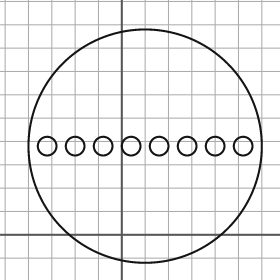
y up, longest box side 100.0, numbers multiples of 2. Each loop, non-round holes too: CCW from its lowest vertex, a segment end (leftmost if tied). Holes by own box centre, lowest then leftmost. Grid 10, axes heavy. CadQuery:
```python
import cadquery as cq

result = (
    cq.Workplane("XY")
    .moveTo(10.0, 38.0)
    .circle(50.0)
    .moveTo(-32.0, 38.0)
    .circle(4.0)
    .moveTo(-20.0, 38.0)
    .circle(4.0)
    .moveTo(-8.0, 38.0)
    .circle(4.0)
    .moveTo(4.0, 38.0)
    .circle(4.0)
    .moveTo(16.0, 38.0)
    .circle(4.0)
    .moveTo(28.0, 38.0)
    .circle(4.0)
    .moveTo(40.0, 38.0)
    .circle(4.0)
    .moveTo(52.0, 38.0)
    .circle(4.0)
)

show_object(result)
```